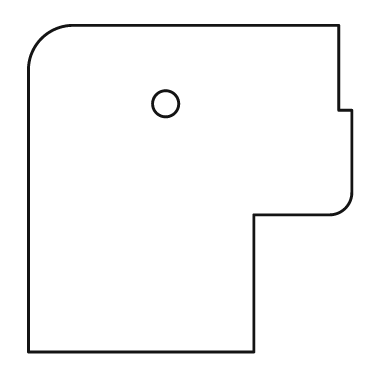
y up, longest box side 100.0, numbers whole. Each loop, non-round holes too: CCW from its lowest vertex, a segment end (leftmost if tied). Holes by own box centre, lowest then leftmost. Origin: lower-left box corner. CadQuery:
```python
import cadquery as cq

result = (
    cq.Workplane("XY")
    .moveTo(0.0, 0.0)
    .lineTo(69.0, 0.0)
    .lineTo(69.0, 42.0)
    .lineTo(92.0, 42.0)
    .threePointArc((97.0, 44.0), (99.0, 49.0))
    .lineTo(99.0, 74.0)
    .lineTo(95.0, 74.0)
    .lineTo(95.0, 100.0)
    .lineTo(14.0, 100.0)
    .threePointArc((4.0, 96.0), (0.0, 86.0))
    .close()
    .moveTo(42.0, 76.0)
    .circle(4.0)
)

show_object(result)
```